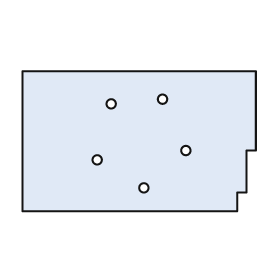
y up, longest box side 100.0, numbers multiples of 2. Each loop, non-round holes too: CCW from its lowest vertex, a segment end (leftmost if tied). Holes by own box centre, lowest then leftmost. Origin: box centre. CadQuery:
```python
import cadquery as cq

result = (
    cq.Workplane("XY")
    .moveTo(-50.0, -30.0)
    .lineTo(42.0, -30.0)
    .lineTo(42.0, -22.0)
    .lineTo(46.0, -22.0)
    .lineTo(46.0, -4.0)
    .lineTo(50.0, -4.0)
    .lineTo(50.0, 30.0)
    .lineTo(-50.0, 30.0)
    .close()
    .moveTo(2.0, -20.0)
    .circle(2.0)
    .moveTo(-18.0, -8.0)
    .circle(2.0)
    .moveTo(20.0, -4.0)
    .circle(2.0)
    .moveTo(-12.0, 16.0)
    .circle(2.0)
    .moveTo(10.0, 18.0)
    .circle(2.0)
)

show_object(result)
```